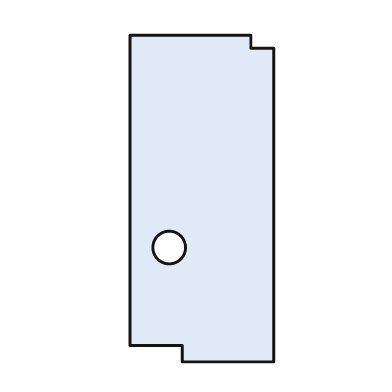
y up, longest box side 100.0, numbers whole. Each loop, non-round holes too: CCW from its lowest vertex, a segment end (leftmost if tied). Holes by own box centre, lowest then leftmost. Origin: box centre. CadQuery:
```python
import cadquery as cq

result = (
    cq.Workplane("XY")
    .moveTo(-6.0, -50.0)
    .lineTo(22.0, -50.0)
    .lineTo(22.0, 46.0)
    .lineTo(15.0, 46.0)
    .lineTo(15.0, 50.0)
    .lineTo(-22.0, 50.0)
    .lineTo(-22.0, -45.0)
    .lineTo(-6.0, -45.0)
    .close()
    .moveTo(-10.0, -15.0)
    .circle(5.0)
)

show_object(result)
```